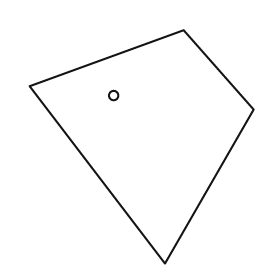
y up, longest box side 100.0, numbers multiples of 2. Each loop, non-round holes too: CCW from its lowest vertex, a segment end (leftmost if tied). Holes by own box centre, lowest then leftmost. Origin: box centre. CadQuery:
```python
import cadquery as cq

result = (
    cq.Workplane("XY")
    .moveTo(10.0, -50.0)
    .lineTo(48.0, 16.0)
    .lineTo(18.0, 50.0)
    .lineTo(-48.0, 26.0)
    .close()
    .moveTo(-12.0, 22.0)
    .circle(2.0)
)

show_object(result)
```